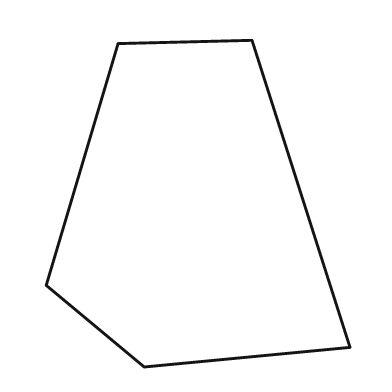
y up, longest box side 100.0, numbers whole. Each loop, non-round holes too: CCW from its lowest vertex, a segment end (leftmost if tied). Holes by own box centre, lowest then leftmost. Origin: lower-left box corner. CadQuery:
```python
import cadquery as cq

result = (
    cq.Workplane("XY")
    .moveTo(30.0, 0.0)
    .lineTo(93.0, 6.0)
    .lineTo(63.0, 100.0)
    .lineTo(22.0, 99.0)
    .lineTo(0.0, 25.0)
    .close()
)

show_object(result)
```